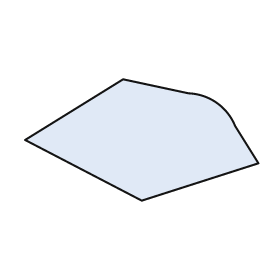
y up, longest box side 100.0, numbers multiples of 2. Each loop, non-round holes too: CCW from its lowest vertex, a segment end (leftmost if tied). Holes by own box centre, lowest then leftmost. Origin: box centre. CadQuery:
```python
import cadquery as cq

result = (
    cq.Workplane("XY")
    .moveTo(0.0, -26.0)
    .lineTo(50.0, -10.0)
    .lineTo(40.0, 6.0)
    .threePointArc((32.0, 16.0), (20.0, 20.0))
    .lineTo(-8.0, 26.0)
    .lineTo(-50.0, 0.0)
    .close()
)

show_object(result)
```